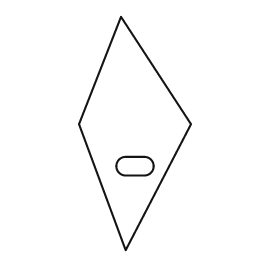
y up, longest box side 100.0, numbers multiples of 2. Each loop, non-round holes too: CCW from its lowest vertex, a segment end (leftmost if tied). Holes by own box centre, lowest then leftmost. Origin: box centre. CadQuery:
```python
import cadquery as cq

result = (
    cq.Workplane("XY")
    .moveTo(-4.0, -50.0)
    .lineTo(24.0, 4.0)
    .lineTo(-6.0, 50.0)
    .lineTo(-24.0, 4.0)
    .close()
    .moveTo(-4.0, -18.0)
    .lineTo(4.0, -18.0)
    .threePointArc((8.0, -14.0), (4.0, -10.0))
    .lineTo(-4.0, -10.0)
    .threePointArc((-8.0, -14.0), (-4.0, -18.0))
    .close()
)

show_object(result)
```